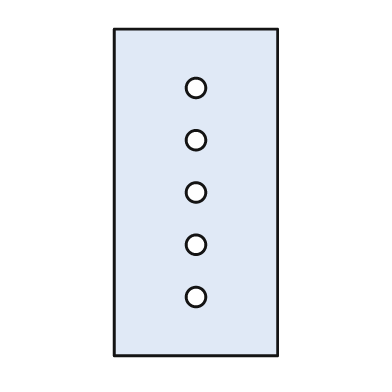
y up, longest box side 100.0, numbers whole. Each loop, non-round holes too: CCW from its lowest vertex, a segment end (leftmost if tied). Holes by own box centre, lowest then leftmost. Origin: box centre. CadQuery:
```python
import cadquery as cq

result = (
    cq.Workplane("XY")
    .moveTo(-25.0, -50.0)
    .lineTo(25.0, -50.0)
    .lineTo(25.0, 50.0)
    .lineTo(-25.0, 50.0)
    .close()
    .moveTo(0.0, -32.0)
    .circle(3.0)
    .moveTo(0.0, -16.0)
    .circle(3.0)
    .moveTo(0.0, 0.0)
    .circle(3.0)
    .moveTo(0.0, 16.0)
    .circle(3.0)
    .moveTo(0.0, 32.0)
    .circle(3.0)
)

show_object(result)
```